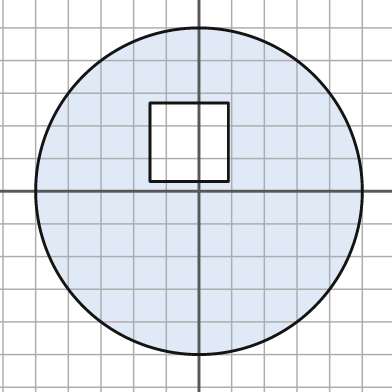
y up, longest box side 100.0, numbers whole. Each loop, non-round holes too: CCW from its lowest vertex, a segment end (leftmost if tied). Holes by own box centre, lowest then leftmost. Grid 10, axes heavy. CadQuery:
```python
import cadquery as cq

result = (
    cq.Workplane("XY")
    .moveTo(0.0, 0.0)
    .circle(50.0)
    .moveTo(-15.0, 3.0)
    .lineTo(9.0, 3.0)
    .lineTo(9.0, 27.0)
    .lineTo(-15.0, 27.0)
    .close()
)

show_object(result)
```